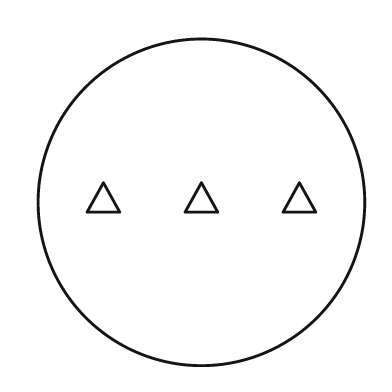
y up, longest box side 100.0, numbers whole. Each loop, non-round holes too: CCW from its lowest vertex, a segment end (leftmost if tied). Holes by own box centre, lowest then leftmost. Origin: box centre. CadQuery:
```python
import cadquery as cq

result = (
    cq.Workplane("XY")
    .moveTo(0.0, 0.0)
    .circle(50.0)
    .moveTo(-35.0, -3.0)
    .lineTo(-25.0, -3.0)
    .lineTo(-30.0, 6.0)
    .close()
    .moveTo(-5.0, -3.0)
    .lineTo(5.0, -3.0)
    .lineTo(0.0, 6.0)
    .close()
    .moveTo(25.0, -3.0)
    .lineTo(35.0, -3.0)
    .lineTo(30.0, 6.0)
    .close()
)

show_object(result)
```